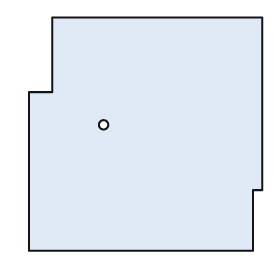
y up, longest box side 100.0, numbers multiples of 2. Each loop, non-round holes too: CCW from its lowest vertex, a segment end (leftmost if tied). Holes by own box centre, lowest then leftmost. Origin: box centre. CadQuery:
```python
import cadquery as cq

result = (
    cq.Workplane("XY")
    .moveTo(-50.0, -50.0)
    .lineTo(46.0, -50.0)
    .lineTo(46.0, -24.0)
    .lineTo(50.0, -24.0)
    .lineTo(50.0, 50.0)
    .lineTo(-40.0, 50.0)
    .lineTo(-40.0, 18.0)
    .lineTo(-50.0, 18.0)
    .close()
    .moveTo(-18.0, 4.0)
    .circle(2.0)
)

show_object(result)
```